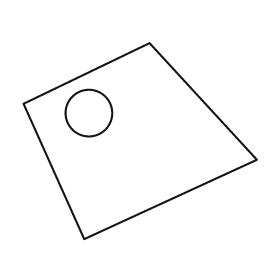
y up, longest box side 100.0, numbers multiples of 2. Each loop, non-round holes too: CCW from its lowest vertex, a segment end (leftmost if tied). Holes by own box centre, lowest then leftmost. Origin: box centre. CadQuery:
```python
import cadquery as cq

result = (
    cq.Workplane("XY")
    .moveTo(-24.0, -42.0)
    .lineTo(50.0, -8.0)
    .lineTo(4.0, 42.0)
    .lineTo(-50.0, 16.0)
    .close()
    .moveTo(-22.0, 12.0)
    .circle(10.0)
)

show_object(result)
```